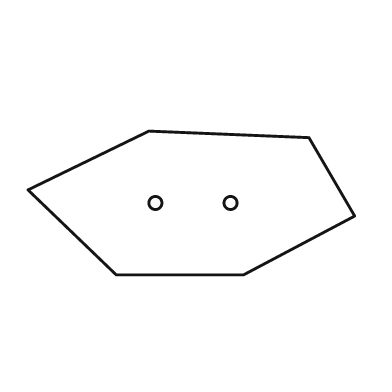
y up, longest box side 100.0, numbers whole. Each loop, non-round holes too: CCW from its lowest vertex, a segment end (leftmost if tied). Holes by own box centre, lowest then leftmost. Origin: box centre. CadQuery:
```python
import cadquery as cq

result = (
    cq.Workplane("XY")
    .moveTo(-23.0, -22.0)
    .lineTo(16.0, -22.0)
    .lineTo(50.0, -4.0)
    .lineTo(36.0, 20.0)
    .lineTo(-13.0, 22.0)
    .lineTo(-50.0, 4.0)
    .close()
    .moveTo(-11.0, 0.0)
    .circle(2.0)
    .moveTo(12.0, 0.0)
    .circle(2.0)
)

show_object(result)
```